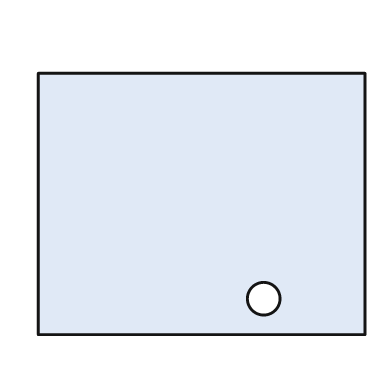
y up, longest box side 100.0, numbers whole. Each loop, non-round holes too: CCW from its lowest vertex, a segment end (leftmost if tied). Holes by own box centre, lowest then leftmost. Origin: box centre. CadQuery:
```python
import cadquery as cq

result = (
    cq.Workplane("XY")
    .moveTo(-50.0, -40.0)
    .lineTo(50.0, -40.0)
    .lineTo(50.0, 40.0)
    .lineTo(-50.0, 40.0)
    .close()
    .moveTo(19.0, -29.0)
    .circle(5.0)
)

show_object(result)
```